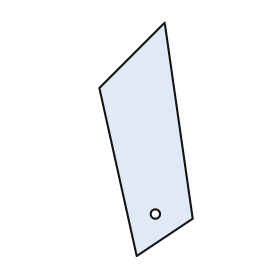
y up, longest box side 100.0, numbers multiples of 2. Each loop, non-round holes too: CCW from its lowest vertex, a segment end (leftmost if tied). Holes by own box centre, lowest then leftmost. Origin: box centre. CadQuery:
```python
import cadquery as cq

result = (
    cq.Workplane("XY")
    .moveTo(-4.0, -50.0)
    .lineTo(20.0, -34.0)
    .lineTo(8.0, 50.0)
    .lineTo(-20.0, 22.0)
    .close()
    .moveTo(4.0, -32.0)
    .circle(2.0)
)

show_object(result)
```